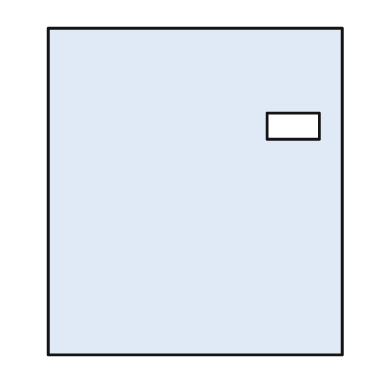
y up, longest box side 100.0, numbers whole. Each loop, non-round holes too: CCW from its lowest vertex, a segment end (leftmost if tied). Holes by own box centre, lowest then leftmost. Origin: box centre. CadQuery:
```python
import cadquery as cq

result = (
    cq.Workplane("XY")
    .moveTo(-45.0, -50.0)
    .lineTo(45.0, -50.0)
    .lineTo(45.0, 50.0)
    .lineTo(-45.0, 50.0)
    .close()
    .moveTo(22.0, 16.0)
    .lineTo(38.0, 16.0)
    .lineTo(38.0, 24.0)
    .lineTo(22.0, 24.0)
    .close()
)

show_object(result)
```